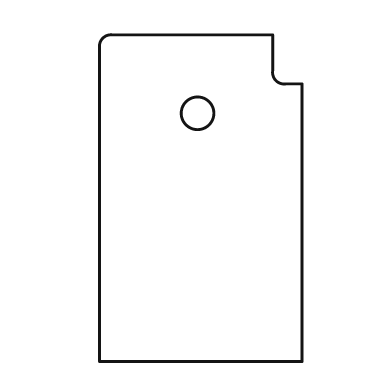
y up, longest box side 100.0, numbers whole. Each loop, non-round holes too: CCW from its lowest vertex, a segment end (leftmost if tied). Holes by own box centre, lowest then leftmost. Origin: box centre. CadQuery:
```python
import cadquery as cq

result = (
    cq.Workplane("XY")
    .moveTo(-31.0, -50.0)
    .lineTo(31.0, -50.0)
    .lineTo(31.0, 35.0)
    .lineTo(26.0, 35.0)
    .threePointArc((23.0, 36.0), (22.0, 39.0))
    .lineTo(22.0, 50.0)
    .lineTo(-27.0, 50.0)
    .threePointArc((-30.0, 49.0), (-31.0, 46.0))
    .close()
    .moveTo(-1.0, 26.0)
    .circle(5.0)
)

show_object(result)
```